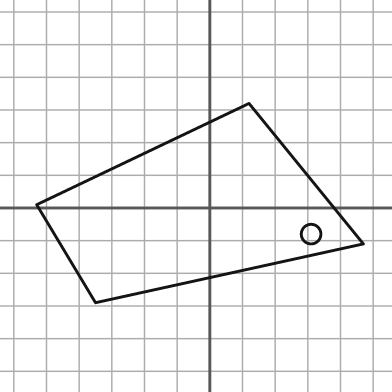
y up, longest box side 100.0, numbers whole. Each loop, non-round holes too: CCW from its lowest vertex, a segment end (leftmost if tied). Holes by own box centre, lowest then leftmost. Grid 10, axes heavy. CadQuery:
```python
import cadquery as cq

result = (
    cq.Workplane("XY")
    .moveTo(-35.0, -29.0)
    .lineTo(47.0, -11.0)
    .lineTo(12.0, 32.0)
    .lineTo(-53.0, 1.0)
    .close()
    .moveTo(31.0, -8.0)
    .circle(3.0)
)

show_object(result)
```